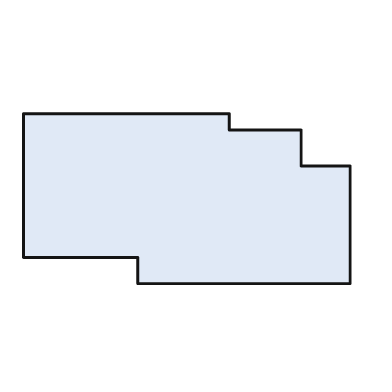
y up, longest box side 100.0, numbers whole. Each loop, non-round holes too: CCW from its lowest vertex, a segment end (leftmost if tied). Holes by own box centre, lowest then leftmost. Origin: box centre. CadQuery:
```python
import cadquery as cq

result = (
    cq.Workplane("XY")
    .moveTo(-15.0, -26.0)
    .lineTo(50.0, -26.0)
    .lineTo(50.0, 10.0)
    .lineTo(35.0, 10.0)
    .lineTo(35.0, 21.0)
    .lineTo(13.0, 21.0)
    .lineTo(13.0, 26.0)
    .lineTo(-50.0, 26.0)
    .lineTo(-50.0, -18.0)
    .lineTo(-15.0, -18.0)
    .close()
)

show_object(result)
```